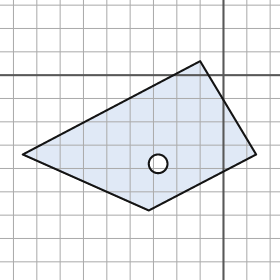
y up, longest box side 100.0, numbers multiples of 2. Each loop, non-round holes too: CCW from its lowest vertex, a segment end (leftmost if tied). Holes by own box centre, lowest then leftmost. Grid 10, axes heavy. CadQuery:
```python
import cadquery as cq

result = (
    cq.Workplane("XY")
    .moveTo(-32.0, -58.0)
    .lineTo(14.0, -34.0)
    .lineTo(-10.0, 6.0)
    .lineTo(-86.0, -34.0)
    .close()
    .moveTo(-28.0, -38.0)
    .circle(4.0)
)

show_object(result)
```